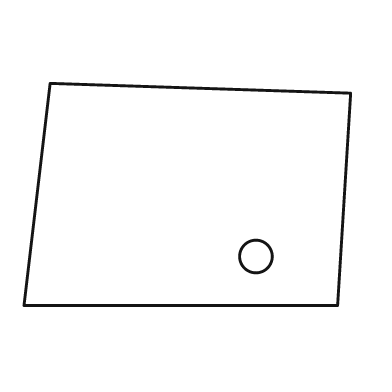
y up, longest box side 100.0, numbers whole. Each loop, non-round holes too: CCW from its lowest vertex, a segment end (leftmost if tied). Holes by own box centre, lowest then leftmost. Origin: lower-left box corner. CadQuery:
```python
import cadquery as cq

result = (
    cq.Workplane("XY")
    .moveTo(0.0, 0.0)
    .lineTo(96.0, 0.0)
    .lineTo(100.0, 65.0)
    .lineTo(8.0, 68.0)
    .close()
    .moveTo(71.0, 15.0)
    .circle(5.0)
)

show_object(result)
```